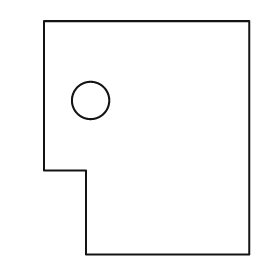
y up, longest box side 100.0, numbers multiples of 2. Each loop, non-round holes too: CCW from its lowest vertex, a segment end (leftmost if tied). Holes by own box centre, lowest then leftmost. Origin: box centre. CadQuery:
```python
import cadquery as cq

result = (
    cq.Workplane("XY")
    .moveTo(-26.0, -50.0)
    .lineTo(44.0, -50.0)
    .lineTo(44.0, 50.0)
    .lineTo(-44.0, 50.0)
    .lineTo(-44.0, -14.0)
    .lineTo(-26.0, -14.0)
    .close()
    .moveTo(-24.0, 16.0)
    .circle(8.0)
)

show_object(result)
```